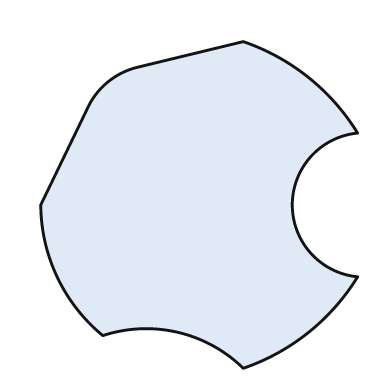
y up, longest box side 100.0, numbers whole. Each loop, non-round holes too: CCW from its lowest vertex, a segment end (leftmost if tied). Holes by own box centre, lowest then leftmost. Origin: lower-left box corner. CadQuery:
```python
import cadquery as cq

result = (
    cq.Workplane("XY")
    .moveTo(62.0, 0.0)
    .threePointArc((82.0, 11.0), (97.0, 28.0))
    .threePointArc((77.0, 50.0), (97.0, 72.0))
    .threePointArc((82.0, 89.0), (62.0, 100.0))
    .lineTo(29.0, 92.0)
    .threePointArc((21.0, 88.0), (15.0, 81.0))
    .lineTo(0.0, 50.0)
    .threePointArc((5.0, 28.0), (19.0, 10.0))
    .threePointArc((42.0, 11.0), (62.0, 0.0))
    .close()
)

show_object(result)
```